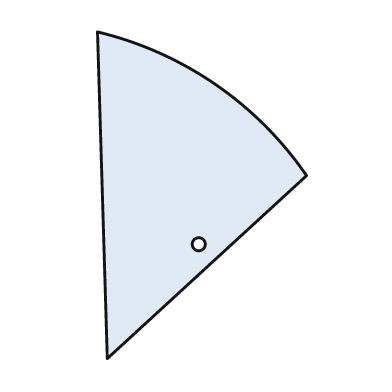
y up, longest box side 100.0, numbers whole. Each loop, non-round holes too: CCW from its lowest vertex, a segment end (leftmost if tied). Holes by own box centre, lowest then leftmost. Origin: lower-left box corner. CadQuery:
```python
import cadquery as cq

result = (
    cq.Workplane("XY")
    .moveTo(3.0, 0.0)
    .lineTo(64.0, 56.0)
    .threePointArc((36.0, 84.0), (0.0, 100.0))
    .close()
    .moveTo(31.0, 35.0)
    .circle(2.0)
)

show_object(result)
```